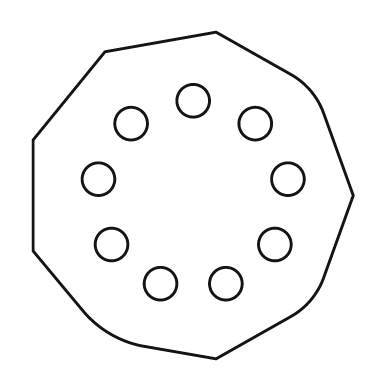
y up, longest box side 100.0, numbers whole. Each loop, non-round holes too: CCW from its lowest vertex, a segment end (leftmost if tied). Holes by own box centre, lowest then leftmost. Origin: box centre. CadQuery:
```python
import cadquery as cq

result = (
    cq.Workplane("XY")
    .moveTo(7.0, -50.0)
    .lineTo(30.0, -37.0)
    .threePointArc((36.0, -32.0), (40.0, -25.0))
    .lineTo(49.0, 0.0)
    .lineTo(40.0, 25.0)
    .threePointArc((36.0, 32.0), (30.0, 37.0))
    .lineTo(7.0, 50.0)
    .lineTo(-27.0, 44.0)
    .lineTo(-49.0, 17.0)
    .lineTo(-49.0, -17.0)
    .lineTo(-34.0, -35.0)
    .threePointArc((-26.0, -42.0), (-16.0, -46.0))
    .close()
    .moveTo(-10.0, -27.0)
    .circle(5.0)
    .moveTo(10.0, -27.0)
    .circle(5.0)
    .moveTo(-25.0, -15.0)
    .circle(5.0)
    .moveTo(25.0, -15.0)
    .circle(5.0)
    .moveTo(-29.0, 5.0)
    .circle(5.0)
    .moveTo(29.0, 5.0)
    .circle(5.0)
    .moveTo(-19.0, 22.0)
    .circle(5.0)
    .moveTo(19.0, 22.0)
    .circle(5.0)
    .moveTo(0.0, 29.0)
    .circle(5.0)
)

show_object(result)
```